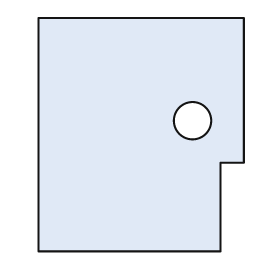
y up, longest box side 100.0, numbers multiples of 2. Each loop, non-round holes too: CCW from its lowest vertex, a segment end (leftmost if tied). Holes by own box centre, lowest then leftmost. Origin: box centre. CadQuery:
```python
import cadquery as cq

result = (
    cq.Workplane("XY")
    .moveTo(-44.0, -50.0)
    .lineTo(34.0, -50.0)
    .lineTo(34.0, -12.0)
    .lineTo(44.0, -12.0)
    .lineTo(44.0, 50.0)
    .lineTo(-44.0, 50.0)
    .close()
    .moveTo(22.0, 6.0)
    .circle(8.0)
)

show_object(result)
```